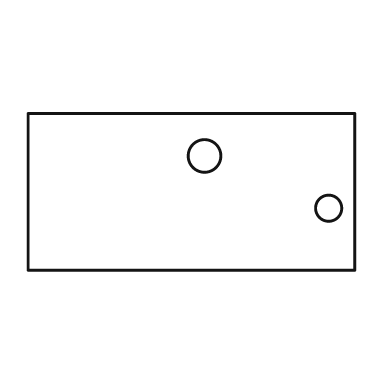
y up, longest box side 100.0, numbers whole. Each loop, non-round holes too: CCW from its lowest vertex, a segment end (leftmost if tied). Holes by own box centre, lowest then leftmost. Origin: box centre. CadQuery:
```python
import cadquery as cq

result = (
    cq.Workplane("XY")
    .moveTo(-50.0, -24.0)
    .lineTo(50.0, -24.0)
    .lineTo(50.0, 24.0)
    .lineTo(-50.0, 24.0)
    .close()
    .moveTo(42.0, -5.0)
    .circle(4.0)
    .moveTo(4.0, 11.0)
    .circle(5.0)
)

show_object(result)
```